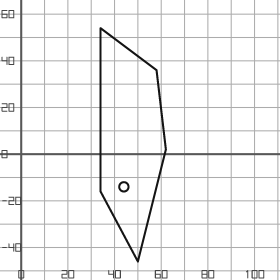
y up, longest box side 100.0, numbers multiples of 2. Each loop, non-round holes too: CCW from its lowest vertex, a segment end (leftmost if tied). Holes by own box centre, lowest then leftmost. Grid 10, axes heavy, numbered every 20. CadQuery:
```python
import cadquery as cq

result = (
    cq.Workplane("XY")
    .moveTo(50.0, -46.0)
    .lineTo(62.0, 2.0)
    .lineTo(58.0, 36.0)
    .lineTo(34.0, 54.0)
    .lineTo(34.0, -16.0)
    .close()
    .moveTo(44.0, -14.0)
    .circle(2.0)
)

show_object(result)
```